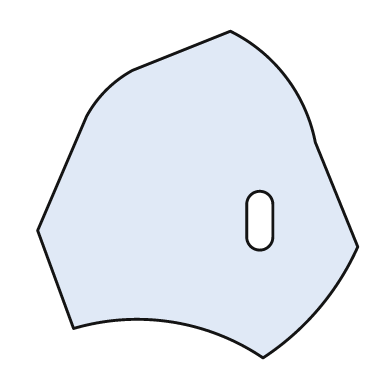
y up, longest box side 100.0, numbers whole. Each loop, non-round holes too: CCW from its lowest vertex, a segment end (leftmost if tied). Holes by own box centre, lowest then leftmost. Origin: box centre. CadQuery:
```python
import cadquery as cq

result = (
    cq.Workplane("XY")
    .moveTo(20.0, -50.0)
    .threePointArc((37.0, -35.0), (49.0, -16.0))
    .lineTo(36.0, 16.0)
    .threePointArc((27.0, 36.0), (10.0, 50.0))
    .lineTo(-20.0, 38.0)
    .threePointArc((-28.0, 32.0), (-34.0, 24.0))
    .lineTo(-49.0, -11.0)
    .lineTo(-38.0, -41.0)
    .threePointArc((-8.0, -39.0), (20.0, -50.0))
    .close()
    .moveTo(15.0, -13.0)
    .threePointArc((19.0, -17.0), (23.0, -13.0))
    .lineTo(23.0, -3.0)
    .threePointArc((19.0, 1.0), (15.0, -3.0))
    .close()
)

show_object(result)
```